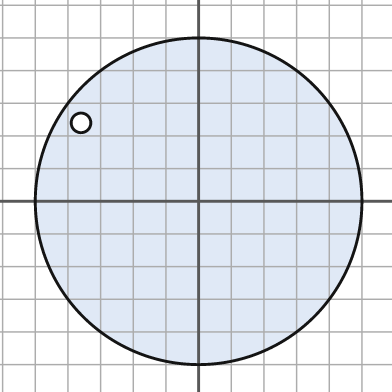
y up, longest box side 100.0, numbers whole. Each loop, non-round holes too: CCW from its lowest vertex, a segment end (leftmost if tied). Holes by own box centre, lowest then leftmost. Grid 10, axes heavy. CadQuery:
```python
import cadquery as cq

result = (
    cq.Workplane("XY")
    .moveTo(0.0, 0.0)
    .circle(50.0)
    .moveTo(-36.0, 24.0)
    .circle(3.0)
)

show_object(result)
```